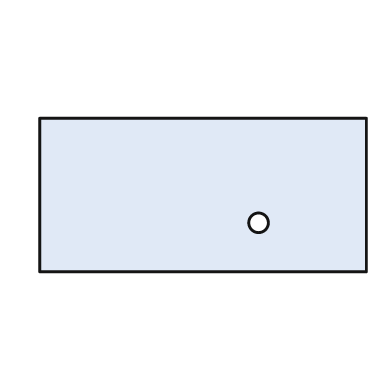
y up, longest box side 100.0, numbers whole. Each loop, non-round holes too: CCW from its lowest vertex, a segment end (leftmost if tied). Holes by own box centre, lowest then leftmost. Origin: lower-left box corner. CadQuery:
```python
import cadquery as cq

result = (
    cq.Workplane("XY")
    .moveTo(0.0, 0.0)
    .lineTo(100.0, 0.0)
    .lineTo(100.0, 47.0)
    .lineTo(0.0, 47.0)
    .close()
    .moveTo(67.0, 15.0)
    .circle(3.0)
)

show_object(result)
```